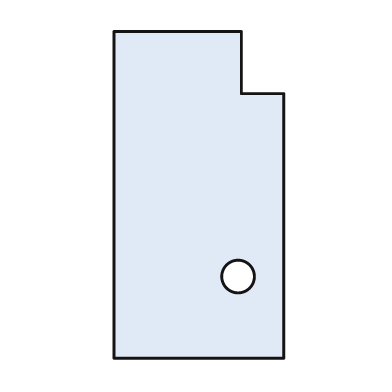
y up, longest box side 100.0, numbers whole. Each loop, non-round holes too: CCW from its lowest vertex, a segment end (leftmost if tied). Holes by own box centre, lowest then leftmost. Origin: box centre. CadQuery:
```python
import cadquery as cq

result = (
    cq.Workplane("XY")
    .moveTo(-26.0, -50.0)
    .lineTo(26.0, -50.0)
    .lineTo(26.0, 31.0)
    .lineTo(13.0, 31.0)
    .lineTo(13.0, 50.0)
    .lineTo(-26.0, 50.0)
    .close()
    .moveTo(12.0, -25.0)
    .circle(5.0)
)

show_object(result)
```